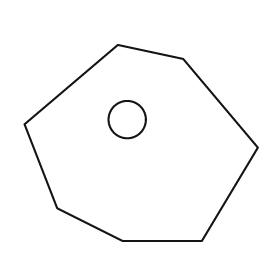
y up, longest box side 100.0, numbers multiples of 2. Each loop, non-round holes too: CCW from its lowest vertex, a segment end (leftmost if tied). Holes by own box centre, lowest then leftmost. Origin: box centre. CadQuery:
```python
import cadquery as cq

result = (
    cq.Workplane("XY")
    .moveTo(-8.0, -42.0)
    .lineTo(26.0, -42.0)
    .lineTo(50.0, -2.0)
    .lineTo(18.0, 36.0)
    .lineTo(-10.0, 42.0)
    .lineTo(-50.0, 8.0)
    .lineTo(-36.0, -28.0)
    .close()
    .moveTo(-6.0, 10.0)
    .circle(8.0)
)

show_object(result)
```